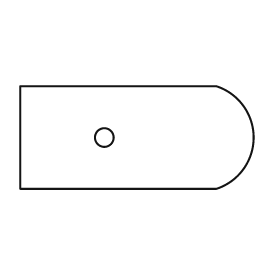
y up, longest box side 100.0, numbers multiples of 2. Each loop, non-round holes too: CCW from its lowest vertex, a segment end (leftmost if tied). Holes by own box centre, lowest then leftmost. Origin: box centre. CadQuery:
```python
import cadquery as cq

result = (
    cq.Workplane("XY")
    .moveTo(-50.0, -22.0)
    .lineTo(34.0, -22.0)
    .threePointArc((50.0, 0.0), (34.0, 22.0))
    .lineTo(-50.0, 22.0)
    .close()
    .moveTo(-14.0, 0.0)
    .circle(4.0)
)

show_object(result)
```